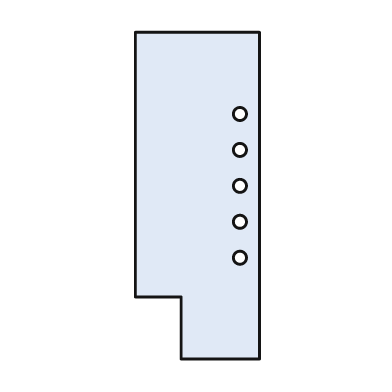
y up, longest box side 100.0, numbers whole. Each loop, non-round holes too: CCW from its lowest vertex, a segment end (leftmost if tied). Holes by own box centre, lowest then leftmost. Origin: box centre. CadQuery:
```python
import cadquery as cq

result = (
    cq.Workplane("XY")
    .moveTo(-5.0, -50.0)
    .lineTo(19.0, -50.0)
    .lineTo(19.0, 50.0)
    .lineTo(-19.0, 50.0)
    .lineTo(-19.0, -31.0)
    .lineTo(-5.0, -31.0)
    .close()
    .moveTo(13.0, -19.0)
    .circle(2.0)
    .moveTo(13.0, -8.0)
    .circle(2.0)
    .moveTo(13.0, 3.0)
    .circle(2.0)
    .moveTo(13.0, 14.0)
    .circle(2.0)
    .moveTo(13.0, 25.0)
    .circle(2.0)
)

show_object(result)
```